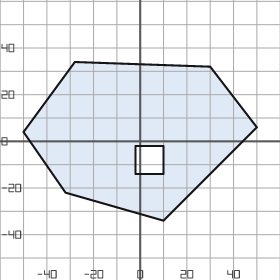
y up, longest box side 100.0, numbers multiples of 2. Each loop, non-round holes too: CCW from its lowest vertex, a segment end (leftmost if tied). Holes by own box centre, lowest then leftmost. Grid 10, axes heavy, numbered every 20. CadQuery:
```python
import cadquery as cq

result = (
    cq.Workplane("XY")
    .moveTo(10.0, -34.0)
    .lineTo(50.0, 6.0)
    .lineTo(30.0, 32.0)
    .lineTo(-28.0, 34.0)
    .lineTo(-50.0, 4.0)
    .lineTo(-32.0, -22.0)
    .close()
    .moveTo(-2.0, -14.0)
    .lineTo(10.0, -14.0)
    .lineTo(10.0, -2.0)
    .lineTo(-2.0, -2.0)
    .close()
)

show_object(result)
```